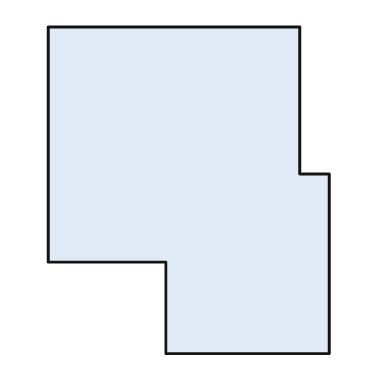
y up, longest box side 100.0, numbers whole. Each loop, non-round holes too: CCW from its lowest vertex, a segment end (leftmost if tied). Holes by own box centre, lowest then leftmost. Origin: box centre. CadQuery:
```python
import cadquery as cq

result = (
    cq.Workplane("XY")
    .moveTo(-7.0, -50.0)
    .lineTo(43.0, -50.0)
    .lineTo(43.0, 5.0)
    .lineTo(34.0, 5.0)
    .lineTo(34.0, 50.0)
    .lineTo(-43.0, 50.0)
    .lineTo(-43.0, -22.0)
    .lineTo(-7.0, -22.0)
    .close()
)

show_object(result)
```